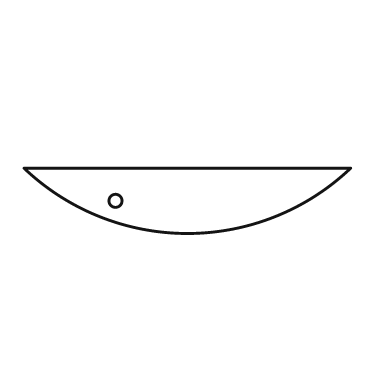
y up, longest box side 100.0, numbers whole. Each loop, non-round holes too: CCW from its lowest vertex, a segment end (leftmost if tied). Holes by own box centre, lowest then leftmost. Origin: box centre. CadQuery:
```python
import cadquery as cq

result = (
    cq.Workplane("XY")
    .moveTo(-50.0, 10.0)
    .threePointArc((0.0, -10.0), (50.0, 10.0))
    .close()
    .moveTo(-22.0, 0.0)
    .circle(2.0)
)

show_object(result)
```